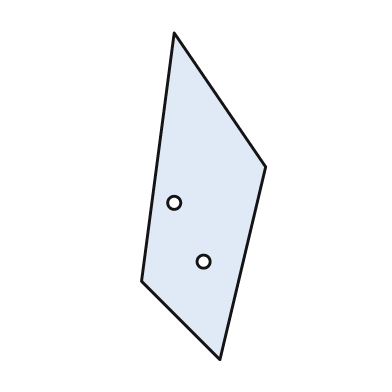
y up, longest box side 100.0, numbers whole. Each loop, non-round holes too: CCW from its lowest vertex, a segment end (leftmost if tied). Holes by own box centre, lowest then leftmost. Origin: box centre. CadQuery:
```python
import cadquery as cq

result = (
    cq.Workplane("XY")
    .moveTo(5.0, -50.0)
    .lineTo(19.0, 9.0)
    .lineTo(-9.0, 50.0)
    .lineTo(-19.0, -26.0)
    .close()
    .moveTo(0.0, -20.0)
    .circle(2.0)
    .moveTo(-9.0, -2.0)
    .circle(2.0)
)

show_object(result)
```